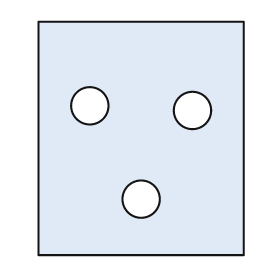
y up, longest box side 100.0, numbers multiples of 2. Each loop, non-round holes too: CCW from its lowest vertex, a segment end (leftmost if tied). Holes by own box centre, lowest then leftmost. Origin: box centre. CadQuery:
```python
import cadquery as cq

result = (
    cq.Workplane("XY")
    .moveTo(-44.0, -50.0)
    .lineTo(44.0, -50.0)
    .lineTo(44.0, 50.0)
    .lineTo(-44.0, 50.0)
    .close()
    .moveTo(0.0, -26.0)
    .circle(8.0)
    .moveTo(22.0, 12.0)
    .circle(8.0)
    .moveTo(-22.0, 14.0)
    .circle(8.0)
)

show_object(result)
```